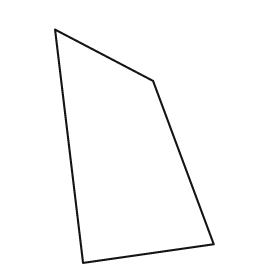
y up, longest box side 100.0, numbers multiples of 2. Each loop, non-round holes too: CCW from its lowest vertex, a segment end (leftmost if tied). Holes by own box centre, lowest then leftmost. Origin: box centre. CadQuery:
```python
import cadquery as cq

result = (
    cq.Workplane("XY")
    .moveTo(-22.0, -50.0)
    .lineTo(34.0, -42.0)
    .lineTo(8.0, 28.0)
    .lineTo(-34.0, 50.0)
    .close()
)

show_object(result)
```